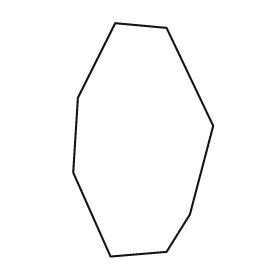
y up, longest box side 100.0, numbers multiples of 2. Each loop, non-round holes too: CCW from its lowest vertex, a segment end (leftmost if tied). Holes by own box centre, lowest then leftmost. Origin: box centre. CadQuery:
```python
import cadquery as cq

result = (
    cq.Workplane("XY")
    .moveTo(-14.0, -50.0)
    .lineTo(10.0, -48.0)
    .lineTo(20.0, -32.0)
    .lineTo(30.0, 6.0)
    .lineTo(10.0, 48.0)
    .lineTo(-12.0, 50.0)
    .lineTo(-28.0, 18.0)
    .lineTo(-30.0, -14.0)
    .close()
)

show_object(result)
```